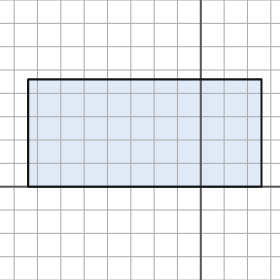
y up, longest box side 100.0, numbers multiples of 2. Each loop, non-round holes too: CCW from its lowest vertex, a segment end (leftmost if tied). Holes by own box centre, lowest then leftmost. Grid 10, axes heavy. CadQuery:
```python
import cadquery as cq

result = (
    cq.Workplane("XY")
    .moveTo(-74.0, 0.0)
    .lineTo(26.0, 0.0)
    .lineTo(26.0, 46.0)
    .lineTo(-74.0, 46.0)
    .close()
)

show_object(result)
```